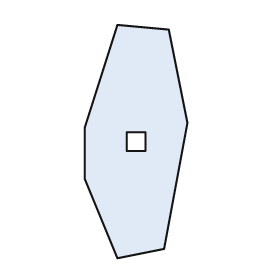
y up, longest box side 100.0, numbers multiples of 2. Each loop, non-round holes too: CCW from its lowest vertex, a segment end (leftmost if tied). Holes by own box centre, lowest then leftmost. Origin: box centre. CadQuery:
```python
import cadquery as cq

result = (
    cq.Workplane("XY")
    .moveTo(-8.0, -50.0)
    .lineTo(12.0, -46.0)
    .lineTo(22.0, 8.0)
    .lineTo(14.0, 48.0)
    .lineTo(-8.0, 50.0)
    .lineTo(-22.0, 6.0)
    .lineTo(-22.0, -16.0)
    .close()
    .moveTo(-4.0, -4.0)
    .lineTo(4.0, -4.0)
    .lineTo(4.0, 4.0)
    .lineTo(-4.0, 4.0)
    .close()
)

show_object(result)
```